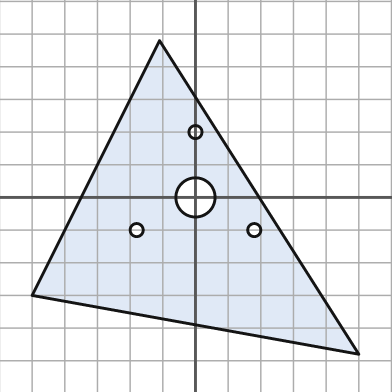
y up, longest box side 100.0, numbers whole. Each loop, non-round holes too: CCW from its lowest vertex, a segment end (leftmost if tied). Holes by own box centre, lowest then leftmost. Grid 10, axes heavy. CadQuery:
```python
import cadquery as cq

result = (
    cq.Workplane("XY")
    .moveTo(50.0, -48.0)
    .lineTo(-11.0, 48.0)
    .lineTo(-50.0, -30.0)
    .close()
    .moveTo(-18.0, -10.0)
    .circle(2.0)
    .moveTo(18.0, -10.0)
    .circle(2.0)
    .moveTo(0.0, 0.0)
    .circle(6.0)
    .moveTo(0.0, 20.0)
    .circle(2.0)
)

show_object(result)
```